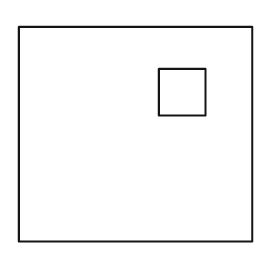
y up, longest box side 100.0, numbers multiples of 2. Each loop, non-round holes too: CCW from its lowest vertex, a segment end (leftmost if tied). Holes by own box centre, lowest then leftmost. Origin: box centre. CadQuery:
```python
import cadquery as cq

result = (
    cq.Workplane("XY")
    .moveTo(-50.0, -46.0)
    .lineTo(50.0, -46.0)
    .lineTo(50.0, 46.0)
    .lineTo(-50.0, 46.0)
    .close()
    .moveTo(10.0, 8.0)
    .lineTo(30.0, 8.0)
    .lineTo(30.0, 28.0)
    .lineTo(10.0, 28.0)
    .close()
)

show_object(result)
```